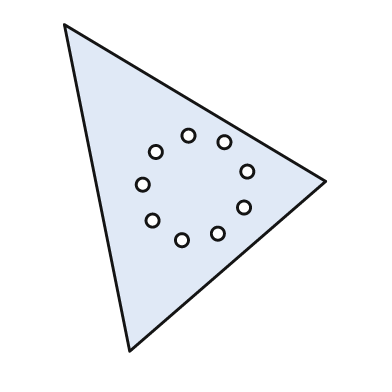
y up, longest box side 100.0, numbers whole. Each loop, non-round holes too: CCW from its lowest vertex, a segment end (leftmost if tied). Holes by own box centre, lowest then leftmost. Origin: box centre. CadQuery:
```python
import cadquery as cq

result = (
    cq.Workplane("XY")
    .moveTo(-20.0, -50.0)
    .lineTo(40.0, 2.0)
    .lineTo(-40.0, 50.0)
    .close()
    .moveTo(-4.0, -16.0)
    .circle(2.0)
    .moveTo(7.0, -14.0)
    .circle(2.0)
    .moveTo(-13.0, -10.0)
    .circle(2.0)
    .moveTo(15.0, -6.0)
    .circle(2.0)
    .moveTo(-16.0, 1.0)
    .circle(2.0)
    .moveTo(16.0, 5.0)
    .circle(2.0)
    .moveTo(-12.0, 11.0)
    .circle(2.0)
    .moveTo(9.0, 14.0)
    .circle(2.0)
    .moveTo(-2.0, 16.0)
    .circle(2.0)
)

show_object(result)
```